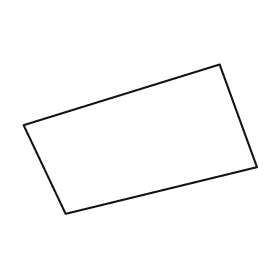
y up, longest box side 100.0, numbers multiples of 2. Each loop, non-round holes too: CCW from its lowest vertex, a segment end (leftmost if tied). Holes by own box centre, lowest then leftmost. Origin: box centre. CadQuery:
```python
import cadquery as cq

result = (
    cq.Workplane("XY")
    .moveTo(-32.0, -32.0)
    .lineTo(50.0, -12.0)
    .lineTo(34.0, 32.0)
    .lineTo(-50.0, 6.0)
    .close()
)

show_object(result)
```